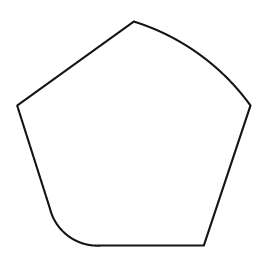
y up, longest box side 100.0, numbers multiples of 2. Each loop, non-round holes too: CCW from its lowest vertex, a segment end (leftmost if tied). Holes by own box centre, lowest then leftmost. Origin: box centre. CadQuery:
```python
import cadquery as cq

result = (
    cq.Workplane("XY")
    .moveTo(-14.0, -48.0)
    .lineTo(30.0, -48.0)
    .lineTo(50.0, 12.0)
    .threePointArc((28.0, 34.0), (0.0, 48.0))
    .lineTo(-50.0, 12.0)
    .lineTo(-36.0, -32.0)
    .threePointArc((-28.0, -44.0), (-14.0, -48.0))
    .close()
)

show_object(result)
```